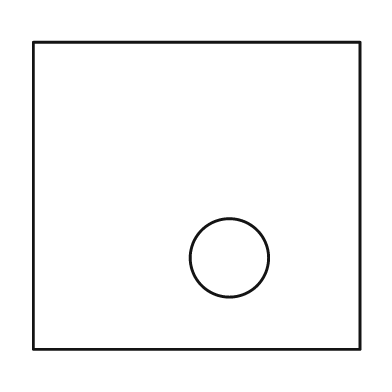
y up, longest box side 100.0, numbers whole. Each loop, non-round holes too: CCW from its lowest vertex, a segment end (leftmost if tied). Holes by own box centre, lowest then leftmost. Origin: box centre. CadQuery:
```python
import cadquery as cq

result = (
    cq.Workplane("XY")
    .moveTo(-50.0, -47.0)
    .lineTo(50.0, -47.0)
    .lineTo(50.0, 47.0)
    .lineTo(-50.0, 47.0)
    .close()
    .moveTo(10.0, -19.0)
    .circle(12.0)
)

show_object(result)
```